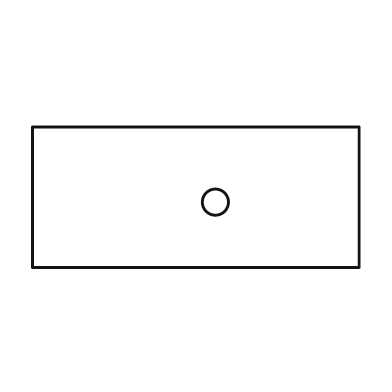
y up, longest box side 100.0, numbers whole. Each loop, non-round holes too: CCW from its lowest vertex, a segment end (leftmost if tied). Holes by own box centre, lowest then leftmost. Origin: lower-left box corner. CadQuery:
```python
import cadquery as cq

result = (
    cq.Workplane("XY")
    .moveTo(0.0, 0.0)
    .lineTo(100.0, 0.0)
    .lineTo(100.0, 43.0)
    .lineTo(0.0, 43.0)
    .close()
    .moveTo(56.0, 20.0)
    .circle(4.0)
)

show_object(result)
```